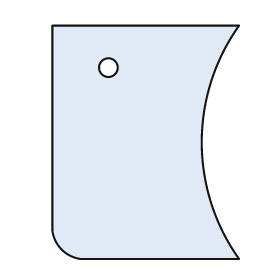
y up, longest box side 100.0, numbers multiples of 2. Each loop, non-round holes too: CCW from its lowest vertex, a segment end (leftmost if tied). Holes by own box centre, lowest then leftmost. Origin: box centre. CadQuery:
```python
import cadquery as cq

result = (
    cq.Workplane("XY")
    .moveTo(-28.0, -50.0)
    .lineTo(40.0, -50.0)
    .threePointArc((24.0, 0.0), (40.0, 50.0))
    .lineTo(-40.0, 50.0)
    .lineTo(-40.0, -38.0)
    .threePointArc((-36.0, -46.0), (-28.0, -50.0))
    .close()
    .moveTo(-16.0, 32.0)
    .circle(4.0)
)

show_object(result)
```